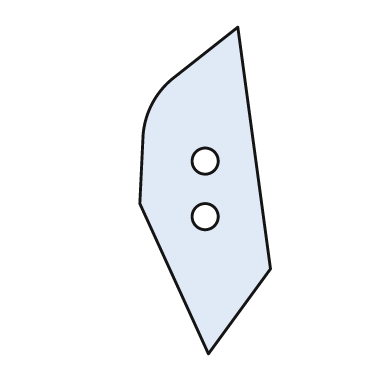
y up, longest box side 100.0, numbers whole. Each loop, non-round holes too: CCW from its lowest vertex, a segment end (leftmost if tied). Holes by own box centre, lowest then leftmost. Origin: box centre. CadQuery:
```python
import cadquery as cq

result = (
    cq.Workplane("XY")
    .moveTo(1.0, -50.0)
    .lineTo(20.0, -24.0)
    .lineTo(10.0, 50.0)
    .lineTo(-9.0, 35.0)
    .threePointArc((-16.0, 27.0), (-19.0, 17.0))
    .lineTo(-20.0, -4.0)
    .close()
    .moveTo(0.0, -8.0)
    .circle(4.0)
    .moveTo(0.0, 9.0)
    .circle(4.0)
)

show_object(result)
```